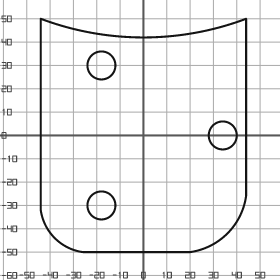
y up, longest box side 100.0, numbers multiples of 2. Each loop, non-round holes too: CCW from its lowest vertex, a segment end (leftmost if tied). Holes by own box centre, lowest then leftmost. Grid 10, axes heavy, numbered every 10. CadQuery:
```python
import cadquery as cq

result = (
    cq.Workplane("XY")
    .moveTo(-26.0, -50.0)
    .lineTo(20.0, -50.0)
    .threePointArc((36.0, -42.0), (44.0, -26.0))
    .lineTo(44.0, 50.0)
    .threePointArc((0.0, 42.0), (-44.0, 50.0))
    .lineTo(-44.0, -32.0)
    .threePointArc((-38.0, -44.0), (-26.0, -50.0))
    .close()
    .moveTo(-18.0, -30.0)
    .circle(6.0)
    .moveTo(34.0, 0.0)
    .circle(6.0)
    .moveTo(-18.0, 30.0)
    .circle(6.0)
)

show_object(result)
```